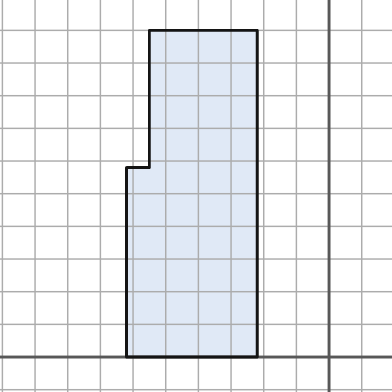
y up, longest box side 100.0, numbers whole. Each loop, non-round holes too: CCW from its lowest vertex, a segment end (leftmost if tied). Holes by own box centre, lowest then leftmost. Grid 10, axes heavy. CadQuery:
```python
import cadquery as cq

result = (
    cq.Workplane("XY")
    .moveTo(-62.0, 0.0)
    .lineTo(-22.0, 0.0)
    .lineTo(-22.0, 100.0)
    .lineTo(-55.0, 100.0)
    .lineTo(-55.0, 58.0)
    .lineTo(-62.0, 58.0)
    .close()
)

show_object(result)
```